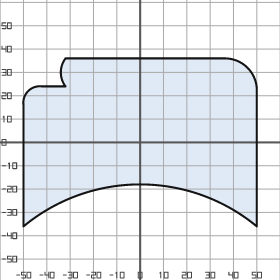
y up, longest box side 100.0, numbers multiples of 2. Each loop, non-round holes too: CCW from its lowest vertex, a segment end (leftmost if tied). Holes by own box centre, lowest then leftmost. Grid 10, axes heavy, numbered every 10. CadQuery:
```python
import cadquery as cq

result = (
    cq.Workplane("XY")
    .moveTo(-50.0, -36.0)
    .threePointArc((0.0, -18.0), (50.0, -36.0))
    .lineTo(50.0, 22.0)
    .threePointArc((46.0, 32.0), (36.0, 36.0))
    .lineTo(-32.0, 36.0)
    .threePointArc((-34.0, 30.0), (-32.0, 24.0))
    .lineTo(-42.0, 24.0)
    .threePointArc((-48.0, 22.0), (-50.0, 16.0))
    .close()
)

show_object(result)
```